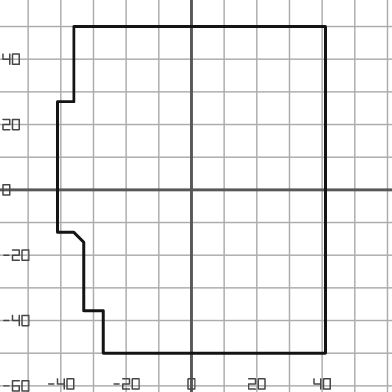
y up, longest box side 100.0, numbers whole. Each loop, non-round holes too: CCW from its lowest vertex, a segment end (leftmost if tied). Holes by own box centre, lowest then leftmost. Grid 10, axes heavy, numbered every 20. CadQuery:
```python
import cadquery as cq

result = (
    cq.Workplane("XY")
    .moveTo(-27.0, -50.0)
    .lineTo(41.0, -50.0)
    .lineTo(41.0, 50.0)
    .lineTo(-36.0, 50.0)
    .lineTo(-36.0, 27.0)
    .lineTo(-41.0, 27.0)
    .lineTo(-41.0, -13.0)
    .lineTo(-36.0, -13.0)
    .lineTo(-33.0, -16.0)
    .lineTo(-33.0, -37.0)
    .lineTo(-27.0, -37.0)
    .close()
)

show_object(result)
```